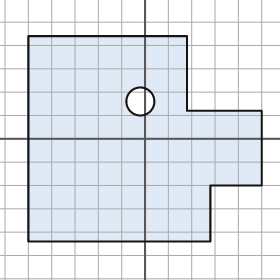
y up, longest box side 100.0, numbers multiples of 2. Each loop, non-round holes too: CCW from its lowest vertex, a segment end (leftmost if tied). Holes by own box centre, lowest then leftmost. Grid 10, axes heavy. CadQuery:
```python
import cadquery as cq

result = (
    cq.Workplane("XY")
    .moveTo(-50.0, -44.0)
    .lineTo(28.0, -44.0)
    .lineTo(28.0, -20.0)
    .lineTo(50.0, -20.0)
    .lineTo(50.0, 12.0)
    .lineTo(18.0, 12.0)
    .lineTo(18.0, 44.0)
    .lineTo(-50.0, 44.0)
    .close()
    .moveTo(-2.0, 16.0)
    .circle(6.0)
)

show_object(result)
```